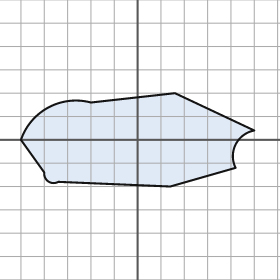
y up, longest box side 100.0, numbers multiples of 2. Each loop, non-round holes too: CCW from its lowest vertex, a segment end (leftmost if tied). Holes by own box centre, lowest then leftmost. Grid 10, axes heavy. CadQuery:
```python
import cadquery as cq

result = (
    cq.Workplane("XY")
    .moveTo(14.0, -20.0)
    .lineTo(42.0, -12.0)
    .threePointArc((42.0, -2.0), (50.0, 4.0))
    .lineTo(16.0, 20.0)
    .lineTo(-20.0, 16.0)
    .threePointArc((-38.0, 14.0), (-50.0, 0.0))
    .lineTo(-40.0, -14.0)
    .threePointArc((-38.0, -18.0), (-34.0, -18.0))
    .close()
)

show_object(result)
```